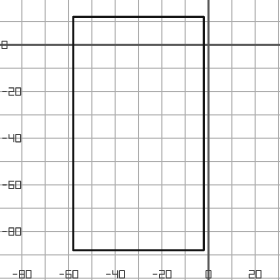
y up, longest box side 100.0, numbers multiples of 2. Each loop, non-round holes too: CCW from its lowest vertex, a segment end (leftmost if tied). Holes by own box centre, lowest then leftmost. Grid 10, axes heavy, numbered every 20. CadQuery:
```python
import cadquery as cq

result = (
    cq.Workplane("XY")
    .moveTo(-58.0, -88.0)
    .lineTo(-2.0, -88.0)
    .lineTo(-2.0, 12.0)
    .lineTo(-58.0, 12.0)
    .close()
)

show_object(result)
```